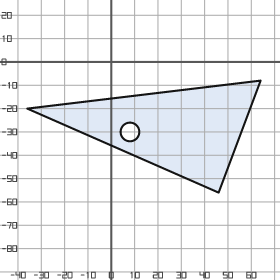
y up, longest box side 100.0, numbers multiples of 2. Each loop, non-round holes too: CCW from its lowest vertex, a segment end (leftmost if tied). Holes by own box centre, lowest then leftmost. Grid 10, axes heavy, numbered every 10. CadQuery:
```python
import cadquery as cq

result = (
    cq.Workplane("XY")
    .moveTo(46.0, -56.0)
    .lineTo(64.0, -8.0)
    .lineTo(-36.0, -20.0)
    .close()
    .moveTo(8.0, -30.0)
    .circle(4.0)
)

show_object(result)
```